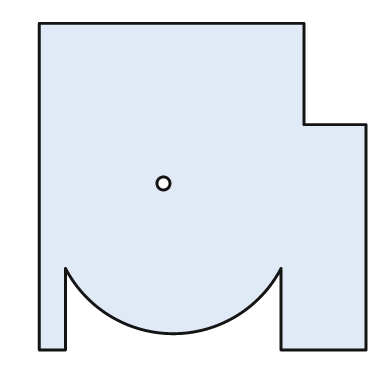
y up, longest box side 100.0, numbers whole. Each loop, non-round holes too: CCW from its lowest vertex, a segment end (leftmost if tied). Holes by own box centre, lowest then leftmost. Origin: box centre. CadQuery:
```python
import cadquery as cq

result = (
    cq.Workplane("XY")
    .moveTo(-50.0, -50.0)
    .lineTo(-42.0, -50.0)
    .lineTo(-42.0, -25.0)
    .threePointArc((-9.0, -45.0), (24.0, -25.0))
    .lineTo(24.0, -50.0)
    .lineTo(50.0, -50.0)
    .lineTo(50.0, 19.0)
    .lineTo(31.0, 19.0)
    .lineTo(31.0, 50.0)
    .lineTo(-50.0, 50.0)
    .close()
    .moveTo(-12.0, 1.0)
    .circle(2.0)
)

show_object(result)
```